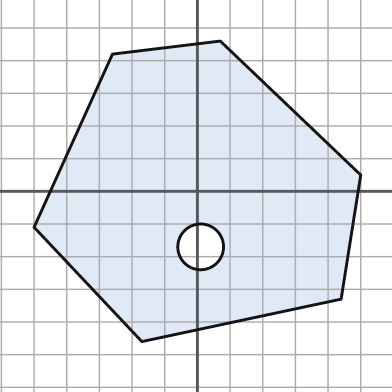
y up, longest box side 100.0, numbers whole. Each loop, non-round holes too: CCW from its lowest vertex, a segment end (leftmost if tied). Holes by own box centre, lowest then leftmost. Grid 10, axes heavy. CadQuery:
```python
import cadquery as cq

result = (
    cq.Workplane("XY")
    .moveTo(-17.0, -46.0)
    .lineTo(44.0, -33.0)
    .lineTo(50.0, 5.0)
    .lineTo(7.0, 46.0)
    .lineTo(-26.0, 42.0)
    .lineTo(-50.0, -11.0)
    .close()
    .moveTo(1.0, -17.0)
    .circle(7.0)
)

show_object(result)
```